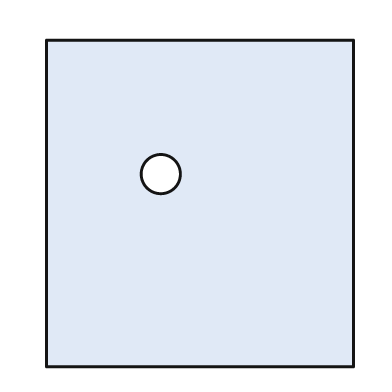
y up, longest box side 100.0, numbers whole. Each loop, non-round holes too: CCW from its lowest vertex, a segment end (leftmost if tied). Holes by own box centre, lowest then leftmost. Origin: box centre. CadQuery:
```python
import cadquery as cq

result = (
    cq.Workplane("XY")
    .moveTo(-47.0, -50.0)
    .lineTo(47.0, -50.0)
    .lineTo(47.0, 50.0)
    .lineTo(-47.0, 50.0)
    .close()
    .moveTo(-12.0, 9.0)
    .circle(6.0)
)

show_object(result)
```